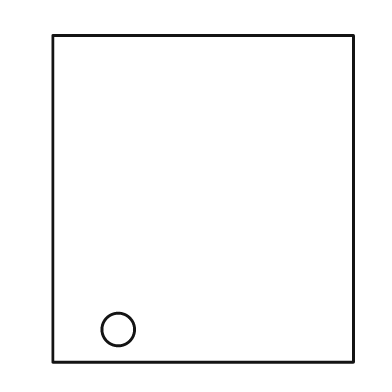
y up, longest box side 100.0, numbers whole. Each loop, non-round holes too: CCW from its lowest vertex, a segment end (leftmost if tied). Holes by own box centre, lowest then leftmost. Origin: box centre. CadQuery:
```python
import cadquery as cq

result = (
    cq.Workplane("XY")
    .moveTo(-46.0, -50.0)
    .lineTo(46.0, -50.0)
    .lineTo(46.0, 50.0)
    .lineTo(-46.0, 50.0)
    .close()
    .moveTo(-26.0, -40.0)
    .circle(5.0)
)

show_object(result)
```